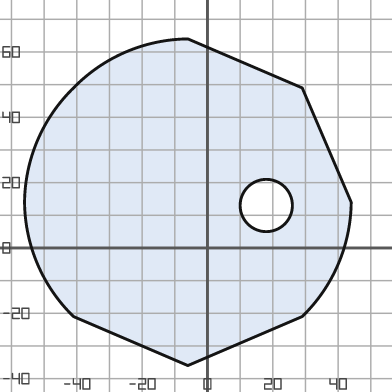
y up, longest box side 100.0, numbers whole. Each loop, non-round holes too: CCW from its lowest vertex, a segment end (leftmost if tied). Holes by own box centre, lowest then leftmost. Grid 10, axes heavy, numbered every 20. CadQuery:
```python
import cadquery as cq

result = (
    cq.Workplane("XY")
    .moveTo(-6.0, -36.0)
    .lineTo(29.0, -21.0)
    .threePointArc((40.0, -5.0), (44.0, 14.0))
    .lineTo(29.0, 49.0)
    .lineTo(-6.0, 64.0)
    .threePointArc((-25.0, 60.0), (-41.0, 49.0))
    .threePointArc((-52.0, 33.0), (-56.0, 14.0))
    .threePointArc((-52.0, -5.0), (-41.0, -21.0))
    .close()
    .moveTo(18.0, 13.0)
    .circle(8.0)
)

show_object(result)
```